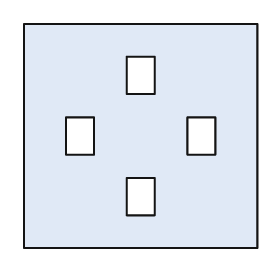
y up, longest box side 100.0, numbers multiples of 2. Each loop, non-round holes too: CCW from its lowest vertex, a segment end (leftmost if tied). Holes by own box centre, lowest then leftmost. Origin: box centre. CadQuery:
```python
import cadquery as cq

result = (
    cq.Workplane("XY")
    .moveTo(-50.0, -48.0)
    .lineTo(50.0, -48.0)
    .lineTo(50.0, 48.0)
    .lineTo(-50.0, 48.0)
    .close()
    .moveTo(-6.0, -34.0)
    .lineTo(6.0, -34.0)
    .lineTo(6.0, -18.0)
    .lineTo(-6.0, -18.0)
    .close()
    .moveTo(-32.0, -8.0)
    .lineTo(-20.0, -8.0)
    .lineTo(-20.0, 8.0)
    .lineTo(-32.0, 8.0)
    .close()
    .moveTo(20.0, -8.0)
    .lineTo(32.0, -8.0)
    .lineTo(32.0, 8.0)
    .lineTo(20.0, 8.0)
    .close()
    .moveTo(-6.0, 18.0)
    .lineTo(6.0, 18.0)
    .lineTo(6.0, 34.0)
    .lineTo(-6.0, 34.0)
    .close()
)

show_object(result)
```